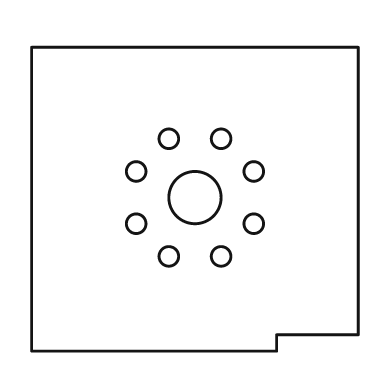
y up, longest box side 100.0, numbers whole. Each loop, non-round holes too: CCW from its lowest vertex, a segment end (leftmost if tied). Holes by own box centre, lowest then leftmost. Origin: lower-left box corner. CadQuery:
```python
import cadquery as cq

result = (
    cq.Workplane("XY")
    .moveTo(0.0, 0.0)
    .lineTo(75.0, 0.0)
    .lineTo(75.0, 5.0)
    .lineTo(100.0, 5.0)
    .lineTo(100.0, 93.0)
    .lineTo(0.0, 93.0)
    .close()
    .moveTo(42.0, 29.0)
    .circle(3.0)
    .moveTo(58.0, 29.0)
    .circle(3.0)
    .moveTo(32.0, 39.0)
    .circle(3.0)
    .moveTo(68.0, 39.0)
    .circle(3.0)
    .moveTo(50.0, 47.0)
    .circle(8.0)
    .moveTo(32.0, 55.0)
    .circle(3.0)
    .moveTo(68.0, 55.0)
    .circle(3.0)
    .moveTo(42.0, 65.0)
    .circle(3.0)
    .moveTo(58.0, 65.0)
    .circle(3.0)
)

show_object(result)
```